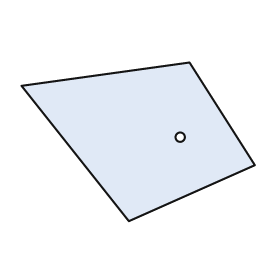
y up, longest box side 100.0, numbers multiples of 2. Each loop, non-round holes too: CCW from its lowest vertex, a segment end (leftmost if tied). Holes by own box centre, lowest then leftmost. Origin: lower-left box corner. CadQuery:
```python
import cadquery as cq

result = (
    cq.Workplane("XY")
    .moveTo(46.0, 0.0)
    .lineTo(100.0, 24.0)
    .lineTo(72.0, 68.0)
    .lineTo(0.0, 58.0)
    .close()
    .moveTo(68.0, 36.0)
    .circle(2.0)
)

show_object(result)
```